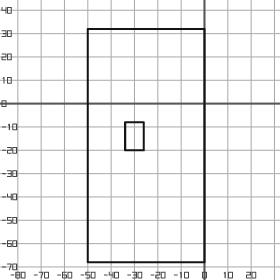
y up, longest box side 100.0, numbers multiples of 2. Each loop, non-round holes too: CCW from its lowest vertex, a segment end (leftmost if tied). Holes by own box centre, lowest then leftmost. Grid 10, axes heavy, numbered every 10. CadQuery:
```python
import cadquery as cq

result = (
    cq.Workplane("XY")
    .moveTo(-50.0, -68.0)
    .lineTo(0.0, -68.0)
    .lineTo(0.0, 32.0)
    .lineTo(-50.0, 32.0)
    .close()
    .moveTo(-34.0, -20.0)
    .lineTo(-26.0, -20.0)
    .lineTo(-26.0, -8.0)
    .lineTo(-34.0, -8.0)
    .close()
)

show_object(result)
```